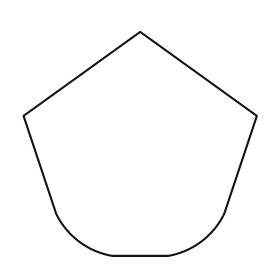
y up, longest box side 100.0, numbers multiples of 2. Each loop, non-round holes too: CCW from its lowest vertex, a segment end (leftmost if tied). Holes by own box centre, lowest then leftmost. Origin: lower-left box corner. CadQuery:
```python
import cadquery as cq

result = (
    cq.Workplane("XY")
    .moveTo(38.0, 0.0)
    .lineTo(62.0, 0.0)
    .threePointArc((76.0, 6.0), (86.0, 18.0))
    .lineTo(100.0, 60.0)
    .lineTo(50.0, 96.0)
    .lineTo(0.0, 60.0)
    .lineTo(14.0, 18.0)
    .threePointArc((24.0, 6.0), (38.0, 0.0))
    .close()
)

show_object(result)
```